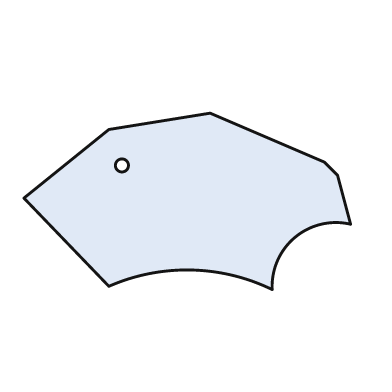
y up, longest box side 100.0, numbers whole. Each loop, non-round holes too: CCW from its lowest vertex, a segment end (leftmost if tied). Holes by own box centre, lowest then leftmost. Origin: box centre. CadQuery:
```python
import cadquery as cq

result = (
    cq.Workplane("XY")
    .moveTo(26.0, -27.0)
    .threePointArc((33.0, -11.0), (50.0, -7.0))
    .lineTo(46.0, 8.0)
    .lineTo(42.0, 12.0)
    .lineTo(7.0, 27.0)
    .lineTo(-24.0, 22.0)
    .lineTo(-50.0, 1.0)
    .lineTo(-24.0, -26.0)
    .threePointArc((1.0, -21.0), (26.0, -27.0))
    .close()
    .moveTo(-20.0, 11.0)
    .circle(2.0)
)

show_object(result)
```